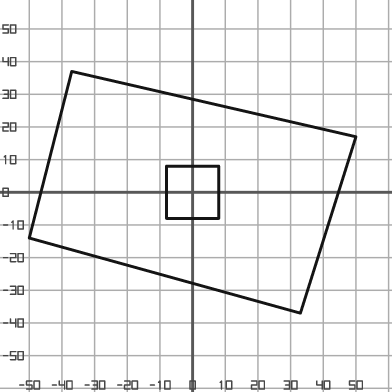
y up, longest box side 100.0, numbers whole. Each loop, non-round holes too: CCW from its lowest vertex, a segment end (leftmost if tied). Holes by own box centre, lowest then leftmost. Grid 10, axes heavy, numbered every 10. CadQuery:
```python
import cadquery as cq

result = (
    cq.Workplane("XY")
    .moveTo(33.0, -37.0)
    .lineTo(50.0, 17.0)
    .lineTo(-37.0, 37.0)
    .lineTo(-50.0, -14.0)
    .close()
    .moveTo(-8.0, -8.0)
    .lineTo(8.0, -8.0)
    .lineTo(8.0, 8.0)
    .lineTo(-8.0, 8.0)
    .close()
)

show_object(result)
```